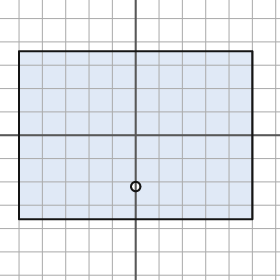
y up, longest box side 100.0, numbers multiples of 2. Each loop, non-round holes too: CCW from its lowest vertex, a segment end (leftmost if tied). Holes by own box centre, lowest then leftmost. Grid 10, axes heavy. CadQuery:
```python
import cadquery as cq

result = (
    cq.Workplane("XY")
    .moveTo(-50.0, -36.0)
    .lineTo(50.0, -36.0)
    .lineTo(50.0, 36.0)
    .lineTo(-50.0, 36.0)
    .close()
    .moveTo(0.0, -22.0)
    .circle(2.0)
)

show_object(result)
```